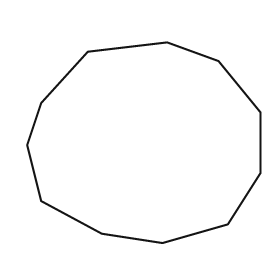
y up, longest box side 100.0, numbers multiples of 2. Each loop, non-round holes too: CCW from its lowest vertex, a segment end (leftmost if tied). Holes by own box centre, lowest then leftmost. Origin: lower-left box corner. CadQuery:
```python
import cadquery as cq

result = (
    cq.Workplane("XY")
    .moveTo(58.0, 0.0)
    .lineTo(86.0, 8.0)
    .lineTo(100.0, 30.0)
    .lineTo(100.0, 56.0)
    .lineTo(82.0, 78.0)
    .lineTo(60.0, 86.0)
    .lineTo(26.0, 82.0)
    .lineTo(6.0, 60.0)
    .lineTo(0.0, 42.0)
    .lineTo(6.0, 18.0)
    .lineTo(32.0, 4.0)
    .close()
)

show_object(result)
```